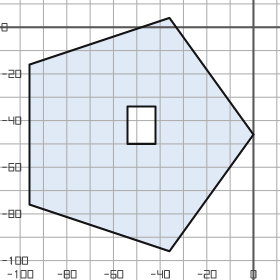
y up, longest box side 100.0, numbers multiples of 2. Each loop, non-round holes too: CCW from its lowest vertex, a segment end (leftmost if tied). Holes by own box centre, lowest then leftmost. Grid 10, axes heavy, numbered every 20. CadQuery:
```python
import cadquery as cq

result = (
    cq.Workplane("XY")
    .moveTo(-36.0, -96.0)
    .lineTo(0.0, -46.0)
    .lineTo(-36.0, 4.0)
    .lineTo(-96.0, -16.0)
    .lineTo(-96.0, -76.0)
    .close()
    .moveTo(-54.0, -50.0)
    .lineTo(-42.0, -50.0)
    .lineTo(-42.0, -34.0)
    .lineTo(-54.0, -34.0)
    .close()
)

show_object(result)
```